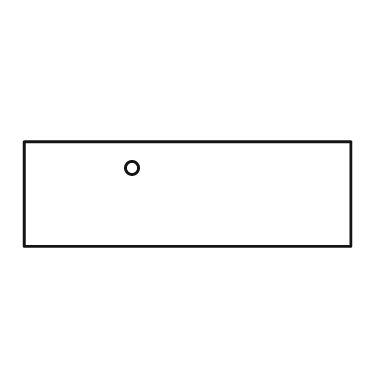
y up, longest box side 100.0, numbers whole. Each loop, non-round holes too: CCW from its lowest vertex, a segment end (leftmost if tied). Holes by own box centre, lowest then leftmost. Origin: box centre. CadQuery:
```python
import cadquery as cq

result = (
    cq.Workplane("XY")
    .moveTo(-50.0, -16.0)
    .lineTo(50.0, -16.0)
    .lineTo(50.0, 16.0)
    .lineTo(-50.0, 16.0)
    .close()
    .moveTo(-17.0, 8.0)
    .circle(2.0)
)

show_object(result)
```